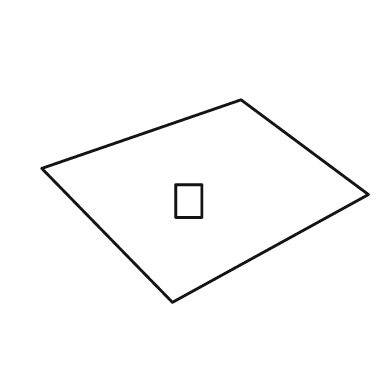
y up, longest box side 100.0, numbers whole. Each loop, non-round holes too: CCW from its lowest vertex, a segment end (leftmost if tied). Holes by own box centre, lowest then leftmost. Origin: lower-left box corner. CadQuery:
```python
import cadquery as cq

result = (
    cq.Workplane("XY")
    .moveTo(40.0, 0.0)
    .lineTo(100.0, 33.0)
    .lineTo(61.0, 62.0)
    .lineTo(0.0, 41.0)
    .close()
    .moveTo(41.0, 26.0)
    .lineTo(49.0, 26.0)
    .lineTo(49.0, 36.0)
    .lineTo(41.0, 36.0)
    .close()
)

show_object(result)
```